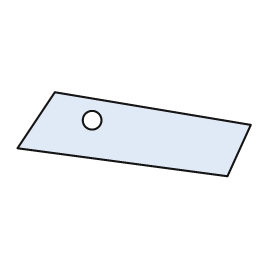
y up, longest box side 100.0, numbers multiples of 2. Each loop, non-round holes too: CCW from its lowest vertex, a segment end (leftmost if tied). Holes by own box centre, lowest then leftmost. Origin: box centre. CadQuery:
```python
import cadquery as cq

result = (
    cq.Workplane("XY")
    .moveTo(40.0, -18.0)
    .lineTo(50.0, 4.0)
    .lineTo(-34.0, 18.0)
    .lineTo(-50.0, -6.0)
    .close()
    .moveTo(-18.0, 6.0)
    .circle(4.0)
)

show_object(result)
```